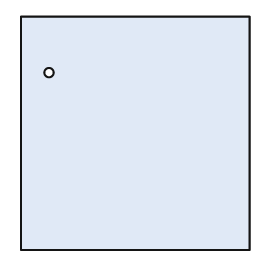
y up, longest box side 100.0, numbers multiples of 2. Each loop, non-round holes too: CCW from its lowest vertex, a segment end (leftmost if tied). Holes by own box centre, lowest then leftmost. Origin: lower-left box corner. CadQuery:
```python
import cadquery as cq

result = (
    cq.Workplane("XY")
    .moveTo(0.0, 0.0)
    .lineTo(98.0, 0.0)
    .lineTo(98.0, 100.0)
    .lineTo(0.0, 100.0)
    .close()
    .moveTo(12.0, 76.0)
    .circle(2.0)
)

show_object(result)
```